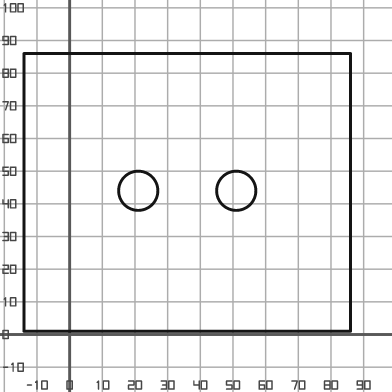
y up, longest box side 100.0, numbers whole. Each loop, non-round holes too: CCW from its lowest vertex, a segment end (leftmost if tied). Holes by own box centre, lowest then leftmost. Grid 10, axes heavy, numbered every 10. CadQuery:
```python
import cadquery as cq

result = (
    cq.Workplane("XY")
    .moveTo(-14.0, 1.0)
    .lineTo(86.0, 1.0)
    .lineTo(86.0, 86.0)
    .lineTo(-14.0, 86.0)
    .close()
    .moveTo(21.0, 44.0)
    .circle(6.0)
    .moveTo(51.0, 44.0)
    .circle(6.0)
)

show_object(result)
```